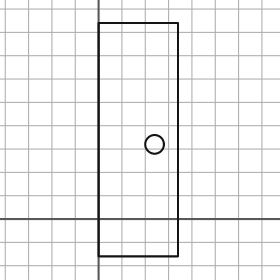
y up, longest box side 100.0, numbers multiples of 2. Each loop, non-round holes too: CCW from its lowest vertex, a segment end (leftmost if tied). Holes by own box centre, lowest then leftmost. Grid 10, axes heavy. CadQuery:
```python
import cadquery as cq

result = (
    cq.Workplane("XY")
    .moveTo(0.0, -16.0)
    .lineTo(34.0, -16.0)
    .lineTo(34.0, 84.0)
    .lineTo(0.0, 84.0)
    .close()
    .moveTo(24.0, 32.0)
    .circle(4.0)
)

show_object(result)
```